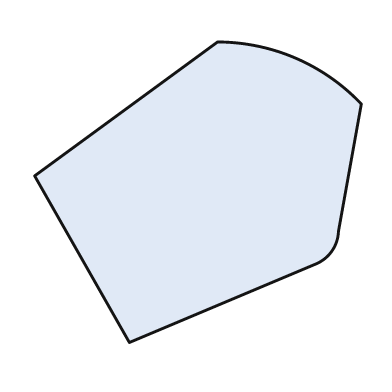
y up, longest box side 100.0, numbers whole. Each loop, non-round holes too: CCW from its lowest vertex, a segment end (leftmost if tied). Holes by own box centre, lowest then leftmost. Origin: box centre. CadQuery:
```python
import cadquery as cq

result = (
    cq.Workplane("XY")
    .moveTo(-21.0, -46.0)
    .lineTo(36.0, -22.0)
    .threePointArc((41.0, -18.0), (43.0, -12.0))
    .lineTo(50.0, 27.0)
    .threePointArc((30.0, 41.0), (6.0, 46.0))
    .lineTo(-50.0, 5.0)
    .close()
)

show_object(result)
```